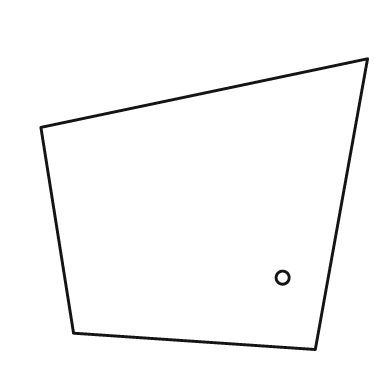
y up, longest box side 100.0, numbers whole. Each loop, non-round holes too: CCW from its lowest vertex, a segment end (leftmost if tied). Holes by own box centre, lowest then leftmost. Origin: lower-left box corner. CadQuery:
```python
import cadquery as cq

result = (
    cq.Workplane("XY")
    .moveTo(84.0, 0.0)
    .lineTo(100.0, 89.0)
    .lineTo(0.0, 68.0)
    .lineTo(10.0, 5.0)
    .close()
    .moveTo(74.0, 22.0)
    .circle(2.0)
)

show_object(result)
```